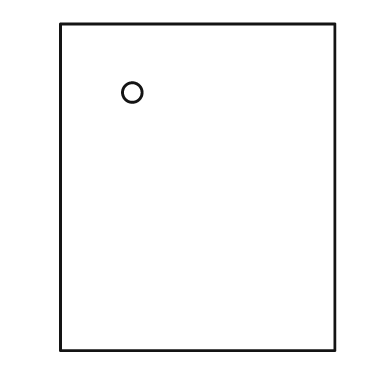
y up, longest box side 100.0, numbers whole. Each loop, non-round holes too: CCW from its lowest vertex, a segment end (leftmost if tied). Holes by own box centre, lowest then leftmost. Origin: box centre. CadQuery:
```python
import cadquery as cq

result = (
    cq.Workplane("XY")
    .moveTo(-42.0, -50.0)
    .lineTo(42.0, -50.0)
    .lineTo(42.0, 50.0)
    .lineTo(-42.0, 50.0)
    .close()
    .moveTo(-20.0, 29.0)
    .circle(3.0)
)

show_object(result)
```